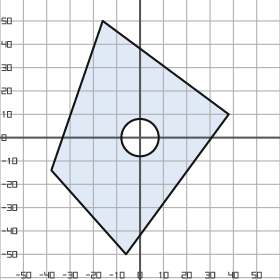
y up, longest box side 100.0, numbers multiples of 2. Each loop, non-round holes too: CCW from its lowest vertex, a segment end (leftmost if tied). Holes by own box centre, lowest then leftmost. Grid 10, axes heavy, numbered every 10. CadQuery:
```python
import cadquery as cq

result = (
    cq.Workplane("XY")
    .moveTo(-6.0, -50.0)
    .lineTo(38.0, 10.0)
    .lineTo(-16.0, 50.0)
    .lineTo(-38.0, -14.0)
    .close()
    .moveTo(0.0, 0.0)
    .circle(8.0)
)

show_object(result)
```